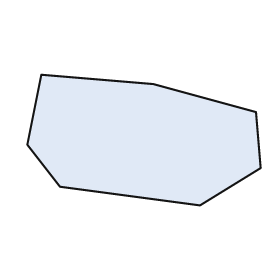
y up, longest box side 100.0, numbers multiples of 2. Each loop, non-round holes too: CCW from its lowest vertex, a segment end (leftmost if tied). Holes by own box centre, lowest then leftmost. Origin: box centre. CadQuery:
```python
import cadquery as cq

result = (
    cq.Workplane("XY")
    .moveTo(24.0, -28.0)
    .lineTo(50.0, -12.0)
    .lineTo(48.0, 12.0)
    .lineTo(4.0, 24.0)
    .lineTo(-44.0, 28.0)
    .lineTo(-50.0, -2.0)
    .lineTo(-36.0, -20.0)
    .close()
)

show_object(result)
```